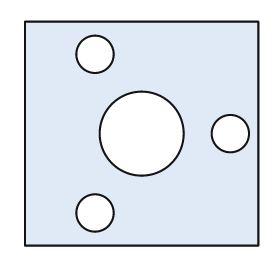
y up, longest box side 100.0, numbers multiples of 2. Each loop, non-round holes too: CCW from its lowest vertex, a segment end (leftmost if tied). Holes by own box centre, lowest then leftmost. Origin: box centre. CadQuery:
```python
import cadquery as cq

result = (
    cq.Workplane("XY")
    .moveTo(-50.0, -48.0)
    .lineTo(50.0, -48.0)
    .lineTo(50.0, 48.0)
    .lineTo(-50.0, 48.0)
    .close()
    .moveTo(-20.0, -34.0)
    .circle(8.0)
    .moveTo(0.0, 0.0)
    .circle(18.0)
    .moveTo(38.0, 0.0)
    .circle(8.0)
    .moveTo(-20.0, 34.0)
    .circle(8.0)
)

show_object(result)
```